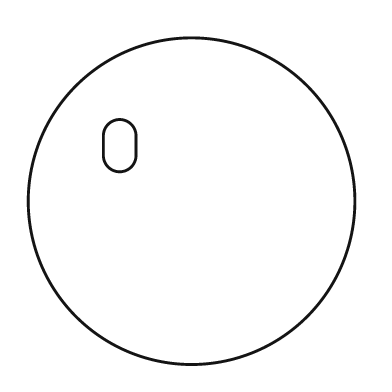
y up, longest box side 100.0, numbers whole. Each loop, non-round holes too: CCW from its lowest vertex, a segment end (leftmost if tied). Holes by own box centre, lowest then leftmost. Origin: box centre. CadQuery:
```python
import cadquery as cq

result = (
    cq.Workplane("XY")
    .moveTo(0.0, 0.0)
    .circle(50.0)
    .moveTo(-27.0, 14.0)
    .threePointArc((-22.0, 9.0), (-17.0, 14.0))
    .lineTo(-17.0, 20.0)
    .threePointArc((-22.0, 25.0), (-27.0, 20.0))
    .close()
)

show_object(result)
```